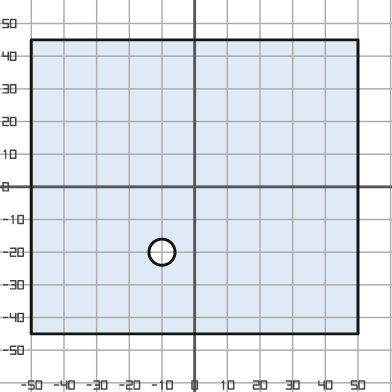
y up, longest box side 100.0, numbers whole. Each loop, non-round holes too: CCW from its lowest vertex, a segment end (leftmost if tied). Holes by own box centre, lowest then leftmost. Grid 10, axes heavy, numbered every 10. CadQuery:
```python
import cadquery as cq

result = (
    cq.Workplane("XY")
    .moveTo(-50.0, -45.0)
    .lineTo(50.0, -45.0)
    .lineTo(50.0, 45.0)
    .lineTo(-50.0, 45.0)
    .close()
    .moveTo(-10.0, -20.0)
    .circle(4.0)
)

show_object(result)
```